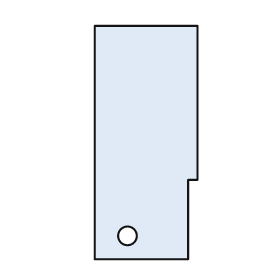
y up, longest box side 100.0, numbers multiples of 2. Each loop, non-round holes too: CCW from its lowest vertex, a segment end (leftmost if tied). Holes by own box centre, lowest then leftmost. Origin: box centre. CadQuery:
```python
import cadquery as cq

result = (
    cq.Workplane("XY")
    .moveTo(-22.0, -50.0)
    .lineTo(18.0, -50.0)
    .lineTo(18.0, -16.0)
    .lineTo(22.0, -16.0)
    .lineTo(22.0, 50.0)
    .lineTo(-22.0, 50.0)
    .close()
    .moveTo(-8.0, -40.0)
    .circle(4.0)
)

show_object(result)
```